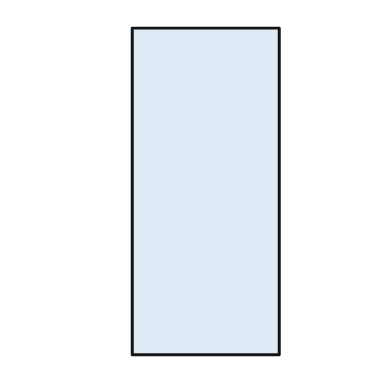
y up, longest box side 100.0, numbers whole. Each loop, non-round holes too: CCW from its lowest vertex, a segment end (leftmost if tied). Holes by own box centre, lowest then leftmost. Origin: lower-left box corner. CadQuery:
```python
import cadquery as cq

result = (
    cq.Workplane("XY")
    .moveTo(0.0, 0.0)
    .lineTo(45.0, 0.0)
    .lineTo(45.0, 100.0)
    .lineTo(0.0, 100.0)
    .close()
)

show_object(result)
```